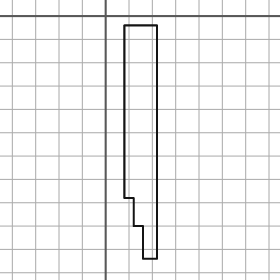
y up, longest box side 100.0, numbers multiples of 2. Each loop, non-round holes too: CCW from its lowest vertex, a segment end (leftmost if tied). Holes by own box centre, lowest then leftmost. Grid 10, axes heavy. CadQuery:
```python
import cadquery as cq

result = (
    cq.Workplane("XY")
    .moveTo(16.0, -104.0)
    .lineTo(22.0, -104.0)
    .lineTo(22.0, -4.0)
    .lineTo(8.0, -4.0)
    .lineTo(8.0, -78.0)
    .lineTo(12.0, -78.0)
    .lineTo(12.0, -90.0)
    .lineTo(16.0, -90.0)
    .close()
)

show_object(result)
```